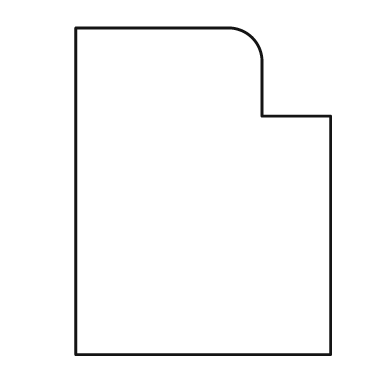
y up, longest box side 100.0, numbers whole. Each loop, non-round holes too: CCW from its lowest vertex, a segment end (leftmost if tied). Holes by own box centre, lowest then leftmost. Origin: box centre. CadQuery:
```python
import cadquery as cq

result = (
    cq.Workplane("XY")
    .moveTo(-39.0, -50.0)
    .lineTo(39.0, -50.0)
    .lineTo(39.0, 23.0)
    .lineTo(18.0, 23.0)
    .lineTo(18.0, 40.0)
    .threePointArc((15.0, 47.0), (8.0, 50.0))
    .lineTo(-39.0, 50.0)
    .close()
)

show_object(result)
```